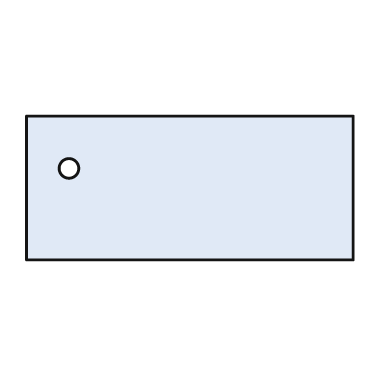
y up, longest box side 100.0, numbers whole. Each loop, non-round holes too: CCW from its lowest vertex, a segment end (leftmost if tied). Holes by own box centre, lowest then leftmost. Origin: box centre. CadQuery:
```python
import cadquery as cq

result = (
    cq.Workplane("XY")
    .moveTo(-50.0, -22.0)
    .lineTo(50.0, -22.0)
    .lineTo(50.0, 22.0)
    .lineTo(-50.0, 22.0)
    .close()
    .moveTo(-37.0, 6.0)
    .circle(3.0)
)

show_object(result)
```